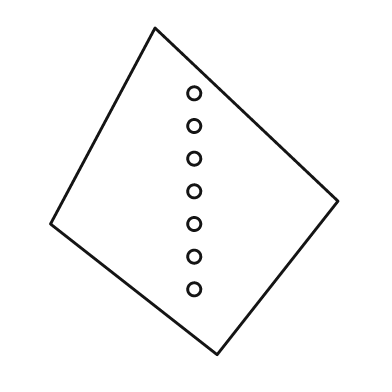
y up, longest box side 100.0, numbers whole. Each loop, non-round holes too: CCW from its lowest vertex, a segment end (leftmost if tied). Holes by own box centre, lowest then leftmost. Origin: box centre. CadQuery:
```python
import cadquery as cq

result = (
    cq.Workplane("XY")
    .moveTo(7.0, -50.0)
    .lineTo(44.0, -3.0)
    .lineTo(-12.0, 50.0)
    .lineTo(-44.0, -10.0)
    .close()
    .moveTo(0.0, -30.0)
    .circle(2.0)
    .moveTo(0.0, -20.0)
    .circle(2.0)
    .moveTo(0.0, -10.0)
    .circle(2.0)
    .moveTo(0.0, 0.0)
    .circle(2.0)
    .moveTo(0.0, 10.0)
    .circle(2.0)
    .moveTo(0.0, 20.0)
    .circle(2.0)
    .moveTo(0.0, 30.0)
    .circle(2.0)
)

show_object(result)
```